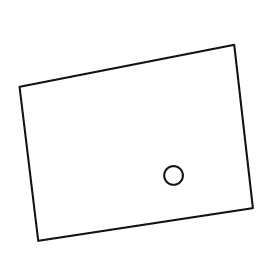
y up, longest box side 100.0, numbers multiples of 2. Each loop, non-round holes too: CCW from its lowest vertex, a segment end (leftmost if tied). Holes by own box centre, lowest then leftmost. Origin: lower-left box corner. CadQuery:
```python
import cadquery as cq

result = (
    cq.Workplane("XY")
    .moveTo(8.0, 0.0)
    .lineTo(100.0, 14.0)
    .lineTo(92.0, 84.0)
    .lineTo(0.0, 66.0)
    .close()
    .moveTo(66.0, 28.0)
    .circle(4.0)
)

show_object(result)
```